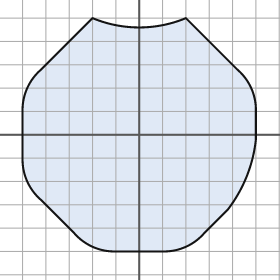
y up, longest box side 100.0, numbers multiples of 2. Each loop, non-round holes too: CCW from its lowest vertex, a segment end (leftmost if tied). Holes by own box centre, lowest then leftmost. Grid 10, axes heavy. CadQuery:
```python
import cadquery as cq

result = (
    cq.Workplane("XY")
    .moveTo(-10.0, -50.0)
    .lineTo(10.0, -50.0)
    .threePointArc((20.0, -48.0), (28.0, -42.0))
    .lineTo(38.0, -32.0)
    .threePointArc((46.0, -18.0), (50.0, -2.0))
    .lineTo(50.0, 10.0)
    .threePointArc((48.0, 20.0), (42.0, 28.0))
    .lineTo(20.0, 50.0)
    .threePointArc((0.0, 46.0), (-20.0, 50.0))
    .lineTo(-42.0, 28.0)
    .threePointArc((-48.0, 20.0), (-50.0, 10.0))
    .lineTo(-50.0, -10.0)
    .threePointArc((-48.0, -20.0), (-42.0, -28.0))
    .lineTo(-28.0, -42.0)
    .threePointArc((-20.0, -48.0), (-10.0, -50.0))
    .close()
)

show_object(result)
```